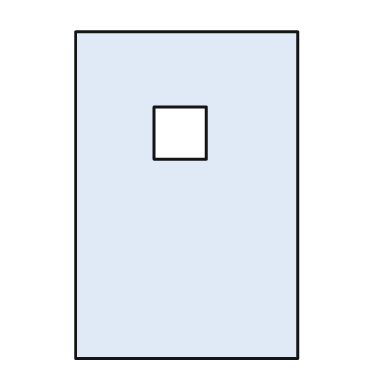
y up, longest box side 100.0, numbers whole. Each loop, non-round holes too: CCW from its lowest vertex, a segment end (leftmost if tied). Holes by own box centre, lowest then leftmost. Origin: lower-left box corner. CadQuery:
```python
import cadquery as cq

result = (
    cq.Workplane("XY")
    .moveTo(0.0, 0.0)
    .lineTo(68.0, 0.0)
    .lineTo(68.0, 100.0)
    .lineTo(0.0, 100.0)
    .close()
    .moveTo(24.0, 61.0)
    .lineTo(40.0, 61.0)
    .lineTo(40.0, 77.0)
    .lineTo(24.0, 77.0)
    .close()
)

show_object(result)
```